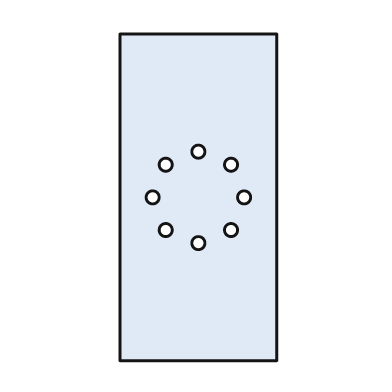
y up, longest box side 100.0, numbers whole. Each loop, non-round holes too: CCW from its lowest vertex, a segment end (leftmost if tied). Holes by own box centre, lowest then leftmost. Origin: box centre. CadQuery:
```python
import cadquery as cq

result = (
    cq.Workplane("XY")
    .moveTo(-24.0, -50.0)
    .lineTo(24.0, -50.0)
    .lineTo(24.0, 50.0)
    .lineTo(-24.0, 50.0)
    .close()
    .moveTo(0.0, -14.0)
    .circle(2.0)
    .moveTo(-10.0, -10.0)
    .circle(2.0)
    .moveTo(10.0, -10.0)
    .circle(2.0)
    .moveTo(-14.0, 0.0)
    .circle(2.0)
    .moveTo(14.0, 0.0)
    .circle(2.0)
    .moveTo(-10.0, 10.0)
    .circle(2.0)
    .moveTo(10.0, 10.0)
    .circle(2.0)
    .moveTo(0.0, 14.0)
    .circle(2.0)
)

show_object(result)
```